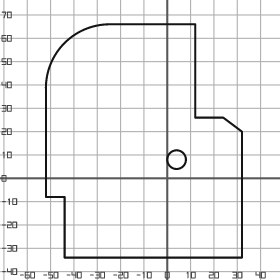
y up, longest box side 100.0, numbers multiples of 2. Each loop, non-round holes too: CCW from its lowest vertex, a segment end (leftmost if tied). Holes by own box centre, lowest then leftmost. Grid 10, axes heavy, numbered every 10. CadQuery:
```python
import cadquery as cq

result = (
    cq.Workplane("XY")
    .moveTo(-44.0, -34.0)
    .lineTo(32.0, -34.0)
    .lineTo(32.0, 20.0)
    .lineTo(24.0, 26.0)
    .lineTo(12.0, 26.0)
    .lineTo(12.0, 66.0)
    .lineTo(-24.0, 66.0)
    .threePointArc((-44.0, 58.0), (-52.0, 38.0))
    .lineTo(-52.0, -8.0)
    .lineTo(-44.0, -8.0)
    .close()
    .moveTo(4.0, 8.0)
    .circle(4.0)
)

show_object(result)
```